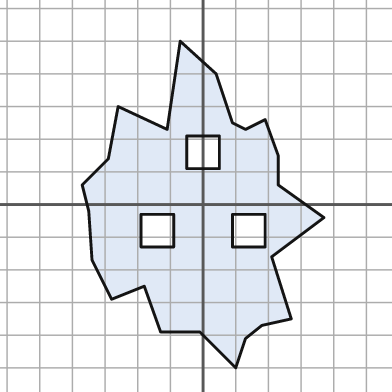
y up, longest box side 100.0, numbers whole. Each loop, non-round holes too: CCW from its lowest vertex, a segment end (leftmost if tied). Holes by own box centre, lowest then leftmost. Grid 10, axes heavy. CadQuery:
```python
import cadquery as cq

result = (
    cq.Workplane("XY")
    .moveTo(10.0, -50.0)
    .lineTo(13.0, -41.0)
    .lineTo(18.0, -37.0)
    .lineTo(27.0, -35.0)
    .lineTo(21.0, -16.0)
    .lineTo(37.0, -4.0)
    .lineTo(23.0, 6.0)
    .lineTo(23.0, 15.0)
    .lineTo(19.0, 26.0)
    .lineTo(13.0, 23.0)
    .lineTo(9.0, 25.0)
    .lineTo(4.0, 40.0)
    .lineTo(-7.0, 50.0)
    .lineTo(-11.0, 23.0)
    .lineTo(-26.0, 30.0)
    .lineTo(-29.0, 14.0)
    .lineTo(-37.0, 6.0)
    .lineTo(-35.0, -2.0)
    .lineTo(-34.0, -17.0)
    .lineTo(-28.0, -29.0)
    .lineTo(-18.0, -25.0)
    .lineTo(-13.0, -39.0)
    .lineTo(-1.0, -39.0)
    .close()
    .moveTo(-19.0, -13.0)
    .lineTo(-9.0, -13.0)
    .lineTo(-9.0, -3.0)
    .lineTo(-19.0, -3.0)
    .close()
    .moveTo(9.0, -13.0)
    .lineTo(19.0, -13.0)
    .lineTo(19.0, -3.0)
    .lineTo(9.0, -3.0)
    .close()
    .moveTo(-5.0, 11.0)
    .lineTo(5.0, 11.0)
    .lineTo(5.0, 21.0)
    .lineTo(-5.0, 21.0)
    .close()
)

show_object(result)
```